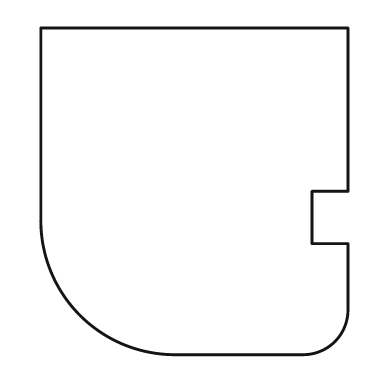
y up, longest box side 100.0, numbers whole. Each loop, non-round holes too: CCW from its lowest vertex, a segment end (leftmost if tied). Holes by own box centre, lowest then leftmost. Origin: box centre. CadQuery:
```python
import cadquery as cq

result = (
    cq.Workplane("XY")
    .moveTo(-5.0, -50.0)
    .lineTo(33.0, -50.0)
    .threePointArc((43.0, -46.0), (47.0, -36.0))
    .lineTo(47.0, -16.0)
    .lineTo(36.0, -16.0)
    .lineTo(36.0, 0.0)
    .lineTo(47.0, 0.0)
    .lineTo(47.0, 50.0)
    .lineTo(-47.0, 50.0)
    .lineTo(-47.0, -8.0)
    .threePointArc((-35.0, -38.0), (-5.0, -50.0))
    .close()
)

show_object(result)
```